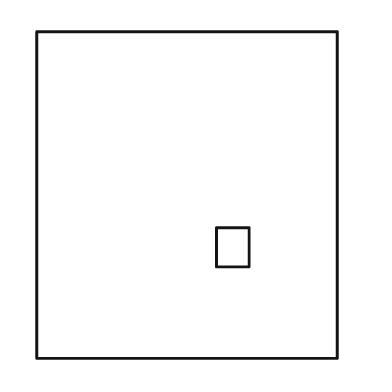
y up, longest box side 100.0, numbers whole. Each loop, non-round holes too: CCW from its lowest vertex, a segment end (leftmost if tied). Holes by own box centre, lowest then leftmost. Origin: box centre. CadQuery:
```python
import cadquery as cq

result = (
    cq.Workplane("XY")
    .moveTo(-46.0, -50.0)
    .lineTo(46.0, -50.0)
    .lineTo(46.0, 50.0)
    .lineTo(-46.0, 50.0)
    .close()
    .moveTo(9.0, -22.0)
    .lineTo(19.0, -22.0)
    .lineTo(19.0, -10.0)
    .lineTo(9.0, -10.0)
    .close()
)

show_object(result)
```